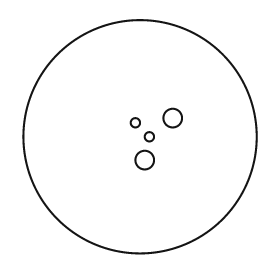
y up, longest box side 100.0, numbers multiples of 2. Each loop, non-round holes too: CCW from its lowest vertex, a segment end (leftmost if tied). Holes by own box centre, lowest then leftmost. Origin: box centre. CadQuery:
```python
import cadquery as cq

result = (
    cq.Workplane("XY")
    .moveTo(0.0, 0.0)
    .circle(50.0)
    .moveTo(2.0, -10.0)
    .circle(4.0)
    .moveTo(4.0, 0.0)
    .circle(2.0)
    .moveTo(-2.0, 6.0)
    .circle(2.0)
    .moveTo(14.0, 8.0)
    .circle(4.0)
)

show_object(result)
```